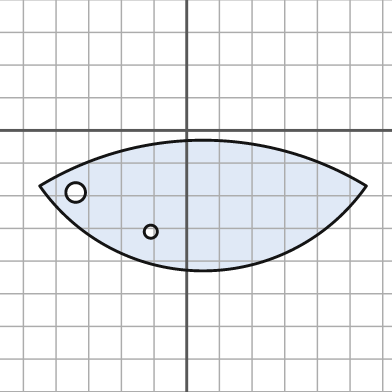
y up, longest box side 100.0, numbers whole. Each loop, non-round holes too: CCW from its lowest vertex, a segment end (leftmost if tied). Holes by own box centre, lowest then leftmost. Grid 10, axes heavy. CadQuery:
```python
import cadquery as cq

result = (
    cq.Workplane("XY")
    .moveTo(-45.0, -17.0)
    .threePointArc((5.0, -43.0), (55.0, -17.0))
    .threePointArc((5.0, -3.0), (-45.0, -17.0))
    .close()
    .moveTo(-11.0, -31.0)
    .circle(2.0)
    .moveTo(-34.0, -19.0)
    .circle(3.0)
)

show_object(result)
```